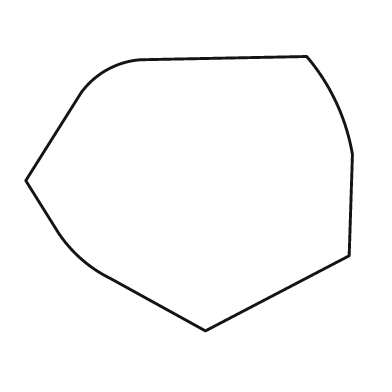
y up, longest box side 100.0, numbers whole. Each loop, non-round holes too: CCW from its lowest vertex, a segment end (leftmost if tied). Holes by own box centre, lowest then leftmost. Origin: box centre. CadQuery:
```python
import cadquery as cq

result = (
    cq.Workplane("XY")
    .moveTo(5.0, -42.0)
    .lineTo(49.0, -19.0)
    .lineTo(50.0, 12.0)
    .threePointArc((45.0, 28.0), (36.0, 42.0))
    .lineTo(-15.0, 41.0)
    .threePointArc((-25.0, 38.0), (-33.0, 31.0))
    .lineTo(-50.0, 4.0)
    .lineTo(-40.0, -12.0)
    .threePointArc((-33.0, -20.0), (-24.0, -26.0))
    .close()
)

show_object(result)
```